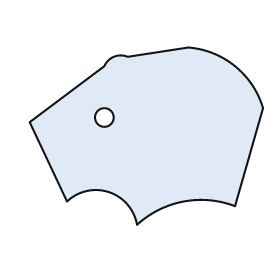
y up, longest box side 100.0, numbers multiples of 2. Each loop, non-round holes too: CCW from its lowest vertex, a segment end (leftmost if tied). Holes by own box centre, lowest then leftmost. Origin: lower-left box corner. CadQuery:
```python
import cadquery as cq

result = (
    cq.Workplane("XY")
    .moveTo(46.0, 0.0)
    .threePointArc((66.0, 10.0), (88.0, 8.0))
    .lineTo(100.0, 50.0)
    .threePointArc((88.0, 68.0), (68.0, 76.0))
    .lineTo(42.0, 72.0)
    .threePointArc((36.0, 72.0), (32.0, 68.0))
    .lineTo(0.0, 44.0)
    .lineTo(16.0, 10.0)
    .threePointArc((34.0, 14.0), (46.0, 0.0))
    .close()
    .moveTo(32.0, 46.0)
    .circle(4.0)
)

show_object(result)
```